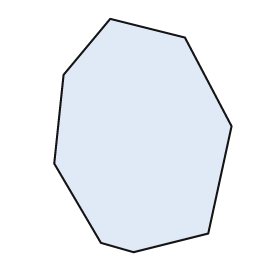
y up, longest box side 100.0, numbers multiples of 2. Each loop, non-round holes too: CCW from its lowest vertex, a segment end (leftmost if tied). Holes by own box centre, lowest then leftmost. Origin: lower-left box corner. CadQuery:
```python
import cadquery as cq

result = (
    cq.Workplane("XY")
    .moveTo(34.0, 0.0)
    .lineTo(66.0, 8.0)
    .lineTo(76.0, 54.0)
    .lineTo(56.0, 92.0)
    .lineTo(24.0, 100.0)
    .lineTo(4.0, 76.0)
    .lineTo(0.0, 38.0)
    .lineTo(20.0, 4.0)
    .close()
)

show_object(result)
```